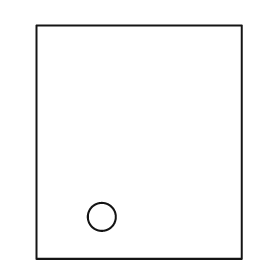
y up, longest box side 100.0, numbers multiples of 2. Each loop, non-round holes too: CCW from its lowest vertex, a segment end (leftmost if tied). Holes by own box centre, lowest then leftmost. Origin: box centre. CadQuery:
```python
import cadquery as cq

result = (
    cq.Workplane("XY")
    .moveTo(-44.0, -50.0)
    .lineTo(44.0, -50.0)
    .lineTo(44.0, 50.0)
    .lineTo(-44.0, 50.0)
    .close()
    .moveTo(-16.0, -32.0)
    .circle(6.0)
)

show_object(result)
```